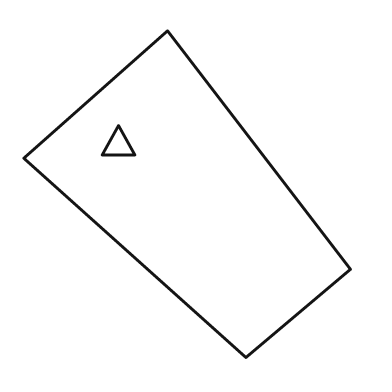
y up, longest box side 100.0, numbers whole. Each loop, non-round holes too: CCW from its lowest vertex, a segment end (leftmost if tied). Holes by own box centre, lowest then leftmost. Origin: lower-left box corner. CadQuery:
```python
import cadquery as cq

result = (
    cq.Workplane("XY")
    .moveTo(68.0, 0.0)
    .lineTo(100.0, 27.0)
    .lineTo(44.0, 100.0)
    .lineTo(0.0, 61.0)
    .close()
    .moveTo(24.0, 62.0)
    .lineTo(34.0, 62.0)
    .lineTo(29.0, 71.0)
    .close()
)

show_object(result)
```